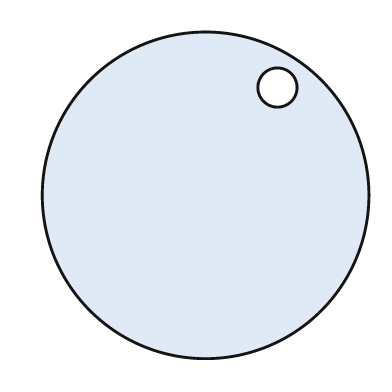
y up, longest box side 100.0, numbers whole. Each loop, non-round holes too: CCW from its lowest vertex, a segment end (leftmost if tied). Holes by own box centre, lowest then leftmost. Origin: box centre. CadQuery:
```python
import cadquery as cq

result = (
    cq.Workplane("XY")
    .moveTo(0.0, 0.0)
    .circle(50.0)
    .moveTo(22.0, 33.0)
    .circle(6.0)
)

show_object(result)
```